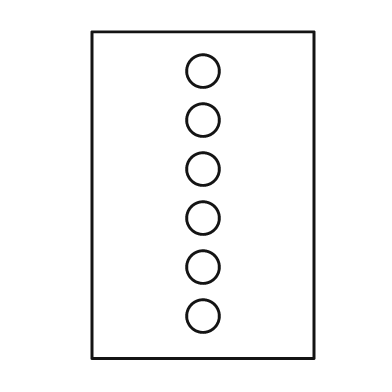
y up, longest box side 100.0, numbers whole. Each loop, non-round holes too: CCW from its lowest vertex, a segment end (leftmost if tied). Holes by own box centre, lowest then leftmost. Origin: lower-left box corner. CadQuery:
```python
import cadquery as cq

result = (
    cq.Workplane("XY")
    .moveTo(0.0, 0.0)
    .lineTo(68.0, 0.0)
    .lineTo(68.0, 100.0)
    .lineTo(0.0, 100.0)
    .close()
    .moveTo(34.0, 13.0)
    .circle(5.0)
    .moveTo(34.0, 28.0)
    .circle(5.0)
    .moveTo(34.0, 43.0)
    .circle(5.0)
    .moveTo(34.0, 58.0)
    .circle(5.0)
    .moveTo(34.0, 73.0)
    .circle(5.0)
    .moveTo(34.0, 88.0)
    .circle(5.0)
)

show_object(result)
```